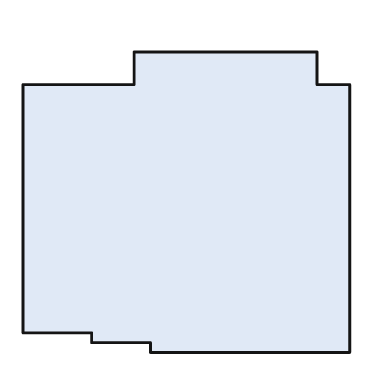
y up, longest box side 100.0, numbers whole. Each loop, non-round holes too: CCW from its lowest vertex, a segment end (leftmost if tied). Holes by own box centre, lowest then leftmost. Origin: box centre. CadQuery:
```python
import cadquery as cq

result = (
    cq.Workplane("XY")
    .moveTo(-11.0, -46.0)
    .lineTo(50.0, -46.0)
    .lineTo(50.0, 36.0)
    .lineTo(40.0, 36.0)
    .lineTo(40.0, 46.0)
    .lineTo(-16.0, 46.0)
    .lineTo(-16.0, 36.0)
    .lineTo(-50.0, 36.0)
    .lineTo(-50.0, -40.0)
    .lineTo(-29.0, -40.0)
    .lineTo(-29.0, -43.0)
    .lineTo(-11.0, -43.0)
    .close()
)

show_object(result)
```